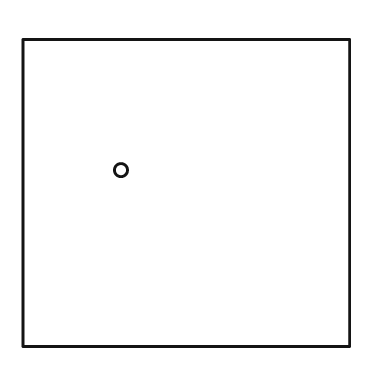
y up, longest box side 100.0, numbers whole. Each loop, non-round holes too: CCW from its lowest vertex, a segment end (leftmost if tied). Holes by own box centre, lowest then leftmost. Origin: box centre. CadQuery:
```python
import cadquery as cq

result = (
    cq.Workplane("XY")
    .moveTo(-50.0, -47.0)
    .lineTo(50.0, -47.0)
    .lineTo(50.0, 47.0)
    .lineTo(-50.0, 47.0)
    .close()
    .moveTo(-20.0, 7.0)
    .circle(2.0)
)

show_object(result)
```